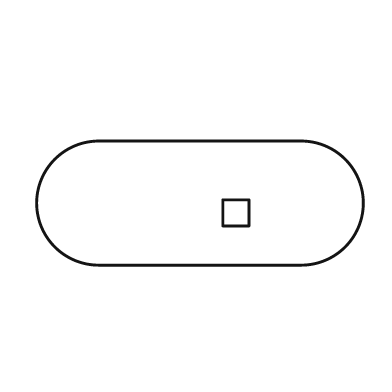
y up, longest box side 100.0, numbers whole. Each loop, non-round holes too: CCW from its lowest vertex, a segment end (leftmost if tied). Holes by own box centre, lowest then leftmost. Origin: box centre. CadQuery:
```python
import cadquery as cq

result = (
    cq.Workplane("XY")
    .moveTo(-31.0, -19.0)
    .lineTo(31.0, -19.0)
    .threePointArc((50.0, 0.0), (31.0, 19.0))
    .lineTo(-31.0, 19.0)
    .threePointArc((-50.0, 0.0), (-31.0, -19.0))
    .close()
    .moveTo(7.0, -7.0)
    .lineTo(15.0, -7.0)
    .lineTo(15.0, 1.0)
    .lineTo(7.0, 1.0)
    .close()
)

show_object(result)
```